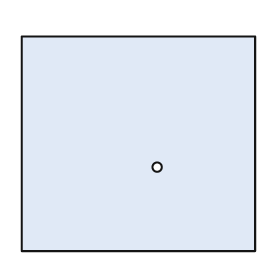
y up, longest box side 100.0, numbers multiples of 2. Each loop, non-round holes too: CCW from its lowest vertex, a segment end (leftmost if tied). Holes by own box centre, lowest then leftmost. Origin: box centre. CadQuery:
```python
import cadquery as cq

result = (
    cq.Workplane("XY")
    .moveTo(-50.0, -46.0)
    .lineTo(50.0, -46.0)
    .lineTo(50.0, 46.0)
    .lineTo(-50.0, 46.0)
    .close()
    .moveTo(8.0, -10.0)
    .circle(2.0)
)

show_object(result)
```